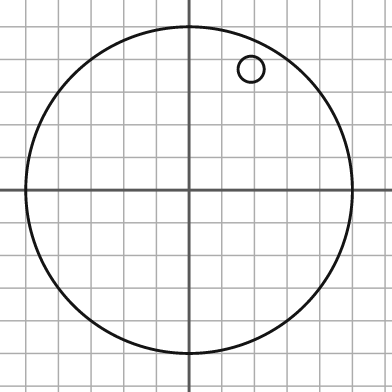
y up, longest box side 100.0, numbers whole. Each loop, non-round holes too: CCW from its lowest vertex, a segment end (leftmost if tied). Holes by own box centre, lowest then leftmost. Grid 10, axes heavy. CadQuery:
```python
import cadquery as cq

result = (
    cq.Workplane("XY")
    .moveTo(0.0, 0.0)
    .circle(50.0)
    .moveTo(19.0, 37.0)
    .circle(4.0)
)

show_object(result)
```